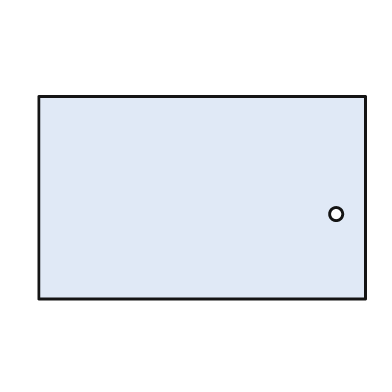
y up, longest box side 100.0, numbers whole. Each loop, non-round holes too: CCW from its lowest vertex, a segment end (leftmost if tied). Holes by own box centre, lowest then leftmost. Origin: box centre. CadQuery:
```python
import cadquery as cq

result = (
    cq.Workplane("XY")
    .moveTo(-50.0, -31.0)
    .lineTo(50.0, -31.0)
    .lineTo(50.0, 31.0)
    .lineTo(-50.0, 31.0)
    .close()
    .moveTo(41.0, -5.0)
    .circle(2.0)
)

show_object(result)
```